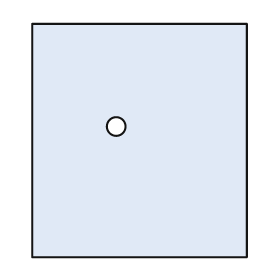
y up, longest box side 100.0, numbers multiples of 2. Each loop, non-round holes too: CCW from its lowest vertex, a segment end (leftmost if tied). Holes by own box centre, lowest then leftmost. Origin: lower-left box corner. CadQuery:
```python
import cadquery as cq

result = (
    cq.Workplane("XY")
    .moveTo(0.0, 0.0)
    .lineTo(92.0, 0.0)
    .lineTo(92.0, 100.0)
    .lineTo(0.0, 100.0)
    .close()
    .moveTo(36.0, 56.0)
    .circle(4.0)
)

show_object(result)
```